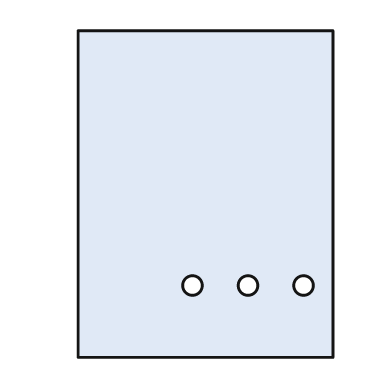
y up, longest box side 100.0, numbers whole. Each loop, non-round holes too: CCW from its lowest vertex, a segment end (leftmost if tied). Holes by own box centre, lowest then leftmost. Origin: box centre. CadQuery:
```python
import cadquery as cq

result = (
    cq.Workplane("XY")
    .moveTo(-39.0, -50.0)
    .lineTo(39.0, -50.0)
    .lineTo(39.0, 50.0)
    .lineTo(-39.0, 50.0)
    .close()
    .moveTo(-4.0, -28.0)
    .circle(3.0)
    .moveTo(13.0, -28.0)
    .circle(3.0)
    .moveTo(30.0, -28.0)
    .circle(3.0)
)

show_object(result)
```